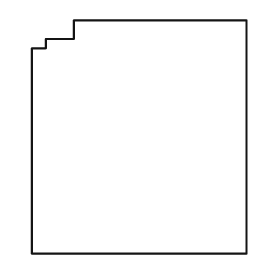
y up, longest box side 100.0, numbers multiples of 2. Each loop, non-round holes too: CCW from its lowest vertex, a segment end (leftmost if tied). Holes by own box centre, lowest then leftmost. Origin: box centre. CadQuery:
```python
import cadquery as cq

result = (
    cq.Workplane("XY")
    .moveTo(-46.0, -50.0)
    .lineTo(46.0, -50.0)
    .lineTo(46.0, 50.0)
    .lineTo(-28.0, 50.0)
    .lineTo(-28.0, 42.0)
    .lineTo(-40.0, 42.0)
    .lineTo(-40.0, 38.0)
    .lineTo(-46.0, 38.0)
    .close()
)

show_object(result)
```